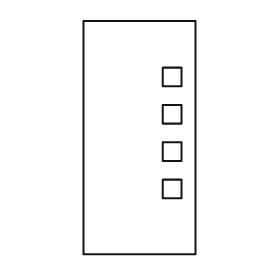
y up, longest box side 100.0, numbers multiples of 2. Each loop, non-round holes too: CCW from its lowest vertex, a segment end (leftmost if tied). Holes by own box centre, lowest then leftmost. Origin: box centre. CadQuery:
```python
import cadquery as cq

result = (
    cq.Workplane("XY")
    .moveTo(-24.0, -50.0)
    .lineTo(24.0, -50.0)
    .lineTo(24.0, 50.0)
    .lineTo(-24.0, 50.0)
    .close()
    .moveTo(10.0, -26.0)
    .lineTo(18.0, -26.0)
    .lineTo(18.0, -18.0)
    .lineTo(10.0, -18.0)
    .close()
    .moveTo(10.0, -10.0)
    .lineTo(18.0, -10.0)
    .lineTo(18.0, -2.0)
    .lineTo(10.0, -2.0)
    .close()
    .moveTo(10.0, 6.0)
    .lineTo(18.0, 6.0)
    .lineTo(18.0, 14.0)
    .lineTo(10.0, 14.0)
    .close()
    .moveTo(10.0, 22.0)
    .lineTo(18.0, 22.0)
    .lineTo(18.0, 30.0)
    .lineTo(10.0, 30.0)
    .close()
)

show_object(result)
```